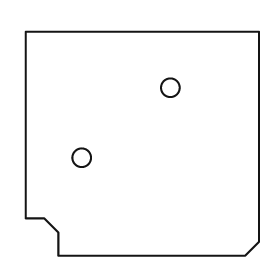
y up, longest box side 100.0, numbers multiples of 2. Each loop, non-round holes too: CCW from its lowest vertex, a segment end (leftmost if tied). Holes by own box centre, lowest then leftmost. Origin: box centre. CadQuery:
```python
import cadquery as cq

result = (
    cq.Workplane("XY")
    .moveTo(-36.0, -48.0)
    .lineTo(44.0, -48.0)
    .lineTo(50.0, -42.0)
    .lineTo(50.0, 48.0)
    .lineTo(-50.0, 48.0)
    .lineTo(-50.0, -32.0)
    .lineTo(-42.0, -32.0)
    .lineTo(-36.0, -38.0)
    .close()
    .moveTo(-26.0, -6.0)
    .circle(4.0)
    .moveTo(12.0, 24.0)
    .circle(4.0)
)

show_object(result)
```